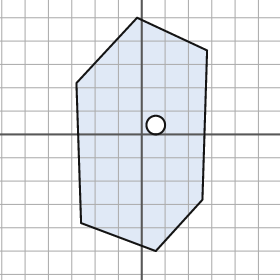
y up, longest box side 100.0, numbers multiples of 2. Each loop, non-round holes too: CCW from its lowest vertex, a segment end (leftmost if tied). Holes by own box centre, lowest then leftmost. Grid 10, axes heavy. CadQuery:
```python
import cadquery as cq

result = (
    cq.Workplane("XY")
    .moveTo(6.0, -50.0)
    .lineTo(26.0, -28.0)
    .lineTo(28.0, 36.0)
    .lineTo(-2.0, 50.0)
    .lineTo(-28.0, 22.0)
    .lineTo(-26.0, -38.0)
    .close()
    .moveTo(6.0, 4.0)
    .circle(4.0)
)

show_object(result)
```